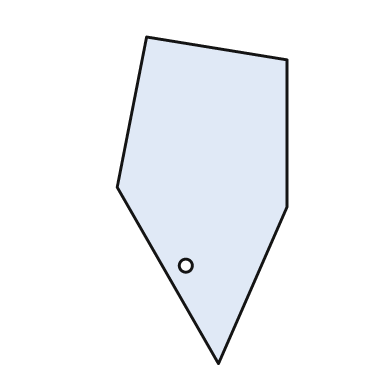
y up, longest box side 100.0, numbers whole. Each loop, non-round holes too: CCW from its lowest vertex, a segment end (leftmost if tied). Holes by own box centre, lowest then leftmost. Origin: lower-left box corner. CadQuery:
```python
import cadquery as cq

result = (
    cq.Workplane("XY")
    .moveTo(31.0, 0.0)
    .lineTo(52.0, 48.0)
    .lineTo(52.0, 93.0)
    .lineTo(9.0, 100.0)
    .lineTo(0.0, 54.0)
    .close()
    .moveTo(21.0, 30.0)
    .circle(2.0)
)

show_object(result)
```